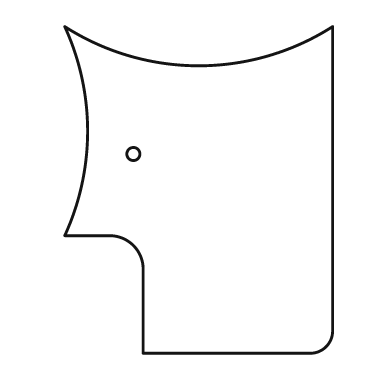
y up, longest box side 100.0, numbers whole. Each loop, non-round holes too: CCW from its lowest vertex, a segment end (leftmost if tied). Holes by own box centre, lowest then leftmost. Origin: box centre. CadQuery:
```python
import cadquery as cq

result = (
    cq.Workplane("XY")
    .moveTo(-17.0, -50.0)
    .lineTo(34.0, -50.0)
    .threePointArc((39.0, -48.0), (41.0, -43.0))
    .lineTo(41.0, 50.0)
    .threePointArc((0.0, 38.0), (-41.0, 50.0))
    .threePointArc((-34.0, 18.0), (-41.0, -14.0))
    .lineTo(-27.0, -14.0)
    .threePointArc((-20.0, -17.0), (-17.0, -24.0))
    .close()
    .moveTo(-20.0, 11.0)
    .circle(2.0)
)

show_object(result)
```